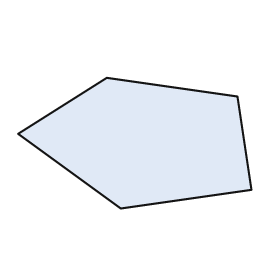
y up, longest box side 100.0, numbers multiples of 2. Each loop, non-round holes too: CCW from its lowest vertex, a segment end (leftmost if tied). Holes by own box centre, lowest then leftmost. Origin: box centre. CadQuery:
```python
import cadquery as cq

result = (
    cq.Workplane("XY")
    .moveTo(-6.0, -28.0)
    .lineTo(50.0, -20.0)
    .lineTo(44.0, 20.0)
    .lineTo(-12.0, 28.0)
    .lineTo(-50.0, 4.0)
    .close()
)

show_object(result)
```